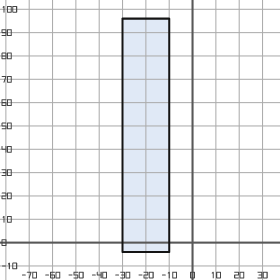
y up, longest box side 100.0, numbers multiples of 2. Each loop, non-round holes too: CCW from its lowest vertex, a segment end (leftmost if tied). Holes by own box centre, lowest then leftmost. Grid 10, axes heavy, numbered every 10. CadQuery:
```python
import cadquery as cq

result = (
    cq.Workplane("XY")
    .moveTo(-30.0, -4.0)
    .lineTo(-10.0, -4.0)
    .lineTo(-10.0, 96.0)
    .lineTo(-30.0, 96.0)
    .close()
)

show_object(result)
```